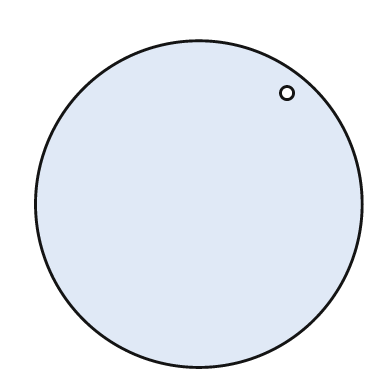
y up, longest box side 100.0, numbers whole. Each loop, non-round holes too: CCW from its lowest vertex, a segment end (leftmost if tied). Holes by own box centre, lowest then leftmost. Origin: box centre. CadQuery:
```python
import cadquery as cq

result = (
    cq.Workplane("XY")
    .moveTo(0.0, 0.0)
    .circle(50.0)
    .moveTo(27.0, 34.0)
    .circle(2.0)
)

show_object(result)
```